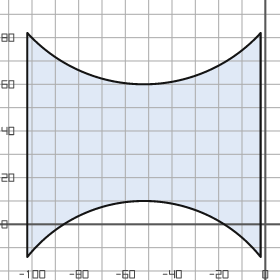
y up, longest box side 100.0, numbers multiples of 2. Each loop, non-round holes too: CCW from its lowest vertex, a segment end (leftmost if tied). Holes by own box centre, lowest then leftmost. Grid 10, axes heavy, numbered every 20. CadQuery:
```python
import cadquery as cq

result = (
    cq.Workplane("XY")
    .moveTo(-102.0, -14.0)
    .threePointArc((-52.0, 10.0), (-2.0, -14.0))
    .lineTo(-2.0, 82.0)
    .threePointArc((-52.0, 60.0), (-102.0, 82.0))
    .close()
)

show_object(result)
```